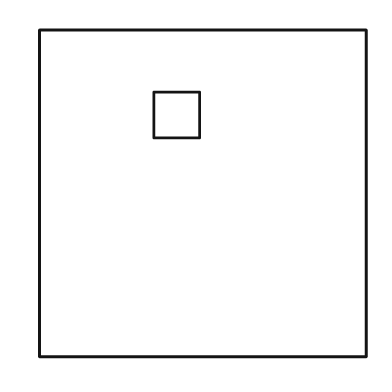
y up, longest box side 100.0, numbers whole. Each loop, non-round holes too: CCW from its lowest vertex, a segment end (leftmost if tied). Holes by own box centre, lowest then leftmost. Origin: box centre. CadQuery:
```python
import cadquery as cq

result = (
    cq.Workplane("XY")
    .moveTo(-50.0, -50.0)
    .lineTo(50.0, -50.0)
    .lineTo(50.0, 50.0)
    .lineTo(-50.0, 50.0)
    .close()
    .moveTo(-15.0, 17.0)
    .lineTo(-1.0, 17.0)
    .lineTo(-1.0, 31.0)
    .lineTo(-15.0, 31.0)
    .close()
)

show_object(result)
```